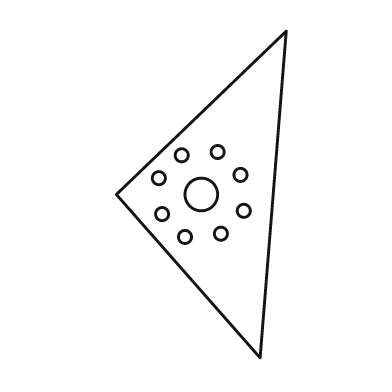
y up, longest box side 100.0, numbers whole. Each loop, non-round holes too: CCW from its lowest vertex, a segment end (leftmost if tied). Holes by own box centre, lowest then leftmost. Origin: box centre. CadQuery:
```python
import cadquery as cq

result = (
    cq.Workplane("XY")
    .moveTo(18.0, -50.0)
    .lineTo(26.0, 50.0)
    .lineTo(-26.0, 0.0)
    .close()
    .moveTo(-5.0, -13.0)
    .circle(2.0)
    .moveTo(6.0, -12.0)
    .circle(2.0)
    .moveTo(-12.0, -6.0)
    .circle(2.0)
    .moveTo(13.0, -5.0)
    .circle(2.0)
    .moveTo(0.0, 0.0)
    .circle(5.0)
    .moveTo(-13.0, 5.0)
    .circle(2.0)
    .moveTo(12.0, 6.0)
    .circle(2.0)
    .moveTo(-6.0, 12.0)
    .circle(2.0)
    .moveTo(5.0, 13.0)
    .circle(2.0)
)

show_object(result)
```